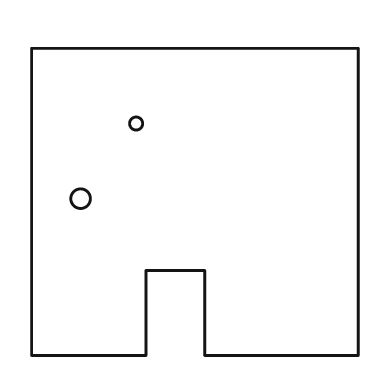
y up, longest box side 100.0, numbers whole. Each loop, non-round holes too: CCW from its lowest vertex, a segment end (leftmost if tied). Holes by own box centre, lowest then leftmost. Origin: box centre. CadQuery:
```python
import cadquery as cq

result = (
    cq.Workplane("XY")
    .moveTo(-50.0, -47.0)
    .lineTo(-15.0, -47.0)
    .lineTo(-15.0, -21.0)
    .lineTo(3.0, -21.0)
    .lineTo(3.0, -47.0)
    .lineTo(50.0, -47.0)
    .lineTo(50.0, 47.0)
    .lineTo(-50.0, 47.0)
    .close()
    .moveTo(-35.0, 1.0)
    .circle(3.0)
    .moveTo(-18.0, 24.0)
    .circle(2.0)
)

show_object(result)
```